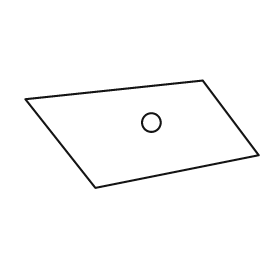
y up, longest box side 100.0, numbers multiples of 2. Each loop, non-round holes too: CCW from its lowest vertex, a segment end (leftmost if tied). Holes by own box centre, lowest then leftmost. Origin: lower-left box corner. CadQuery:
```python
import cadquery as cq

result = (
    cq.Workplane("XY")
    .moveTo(30.0, 0.0)
    .lineTo(100.0, 14.0)
    .lineTo(76.0, 46.0)
    .lineTo(0.0, 38.0)
    .close()
    .moveTo(54.0, 28.0)
    .circle(4.0)
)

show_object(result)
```